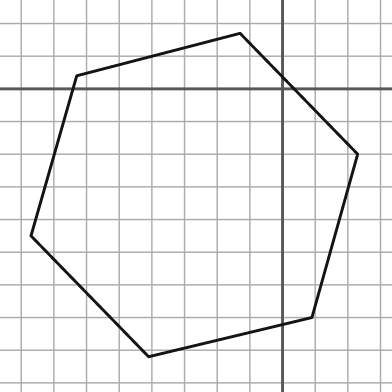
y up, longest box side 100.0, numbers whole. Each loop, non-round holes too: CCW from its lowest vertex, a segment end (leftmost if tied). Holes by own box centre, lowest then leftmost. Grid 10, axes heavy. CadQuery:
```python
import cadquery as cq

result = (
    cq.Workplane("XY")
    .moveTo(-41.0, -82.0)
    .lineTo(9.0, -70.0)
    .lineTo(23.0, -20.0)
    .lineTo(-13.0, 17.0)
    .lineTo(-63.0, 4.0)
    .lineTo(-77.0, -45.0)
    .close()
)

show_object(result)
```